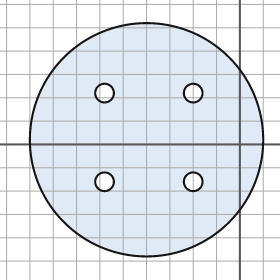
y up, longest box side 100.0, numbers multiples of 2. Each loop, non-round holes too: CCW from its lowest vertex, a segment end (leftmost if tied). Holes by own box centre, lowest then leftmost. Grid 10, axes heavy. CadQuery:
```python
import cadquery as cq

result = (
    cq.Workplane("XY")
    .moveTo(-40.0, 2.0)
    .circle(50.0)
    .moveTo(-58.0, -16.0)
    .circle(4.0)
    .moveTo(-20.0, -16.0)
    .circle(4.0)
    .moveTo(-58.0, 22.0)
    .circle(4.0)
    .moveTo(-20.0, 22.0)
    .circle(4.0)
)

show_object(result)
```